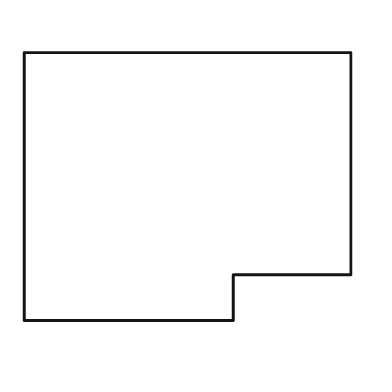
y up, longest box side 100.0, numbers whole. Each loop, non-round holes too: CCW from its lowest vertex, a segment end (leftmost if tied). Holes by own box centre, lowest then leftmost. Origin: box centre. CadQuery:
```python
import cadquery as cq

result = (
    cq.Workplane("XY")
    .moveTo(-50.0, -41.0)
    .lineTo(14.0, -41.0)
    .lineTo(14.0, -27.0)
    .lineTo(50.0, -27.0)
    .lineTo(50.0, 41.0)
    .lineTo(-50.0, 41.0)
    .close()
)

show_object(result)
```